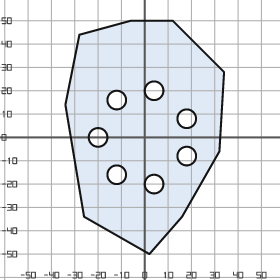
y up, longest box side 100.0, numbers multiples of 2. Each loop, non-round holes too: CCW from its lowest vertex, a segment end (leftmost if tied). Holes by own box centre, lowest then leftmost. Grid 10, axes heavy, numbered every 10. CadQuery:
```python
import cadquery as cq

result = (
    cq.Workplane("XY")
    .moveTo(2.0, -50.0)
    .lineTo(16.0, -34.0)
    .lineTo(32.0, -6.0)
    .lineTo(34.0, 28.0)
    .lineTo(12.0, 50.0)
    .lineTo(-6.0, 50.0)
    .lineTo(-28.0, 44.0)
    .lineTo(-34.0, 14.0)
    .lineTo(-26.0, -34.0)
    .close()
    .moveTo(4.0, -20.0)
    .circle(4.0)
    .moveTo(-12.0, -16.0)
    .circle(4.0)
    .moveTo(18.0, -8.0)
    .circle(4.0)
    .moveTo(-20.0, 0.0)
    .circle(4.0)
    .moveTo(18.0, 8.0)
    .circle(4.0)
    .moveTo(-12.0, 16.0)
    .circle(4.0)
    .moveTo(4.0, 20.0)
    .circle(4.0)
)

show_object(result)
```